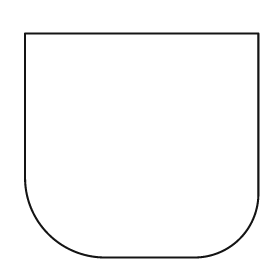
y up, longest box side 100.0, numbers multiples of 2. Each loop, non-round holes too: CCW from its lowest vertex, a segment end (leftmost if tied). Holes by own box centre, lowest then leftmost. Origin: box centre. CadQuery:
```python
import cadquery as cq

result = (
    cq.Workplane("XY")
    .moveTo(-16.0, -48.0)
    .lineTo(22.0, -48.0)
    .threePointArc((42.0, -40.0), (50.0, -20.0))
    .lineTo(50.0, 48.0)
    .lineTo(-50.0, 48.0)
    .lineTo(-50.0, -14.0)
    .threePointArc((-40.0, -38.0), (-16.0, -48.0))
    .close()
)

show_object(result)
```